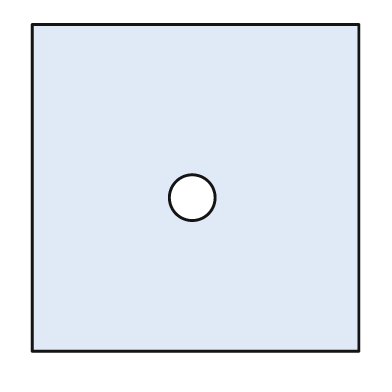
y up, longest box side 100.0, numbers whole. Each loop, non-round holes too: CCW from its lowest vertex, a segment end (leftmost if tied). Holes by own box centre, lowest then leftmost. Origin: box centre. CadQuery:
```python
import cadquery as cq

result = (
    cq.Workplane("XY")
    .moveTo(-50.0, -50.0)
    .lineTo(50.0, -50.0)
    .lineTo(50.0, 50.0)
    .lineTo(-50.0, 50.0)
    .close()
    .moveTo(-1.0, -3.0)
    .circle(7.0)
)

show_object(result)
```